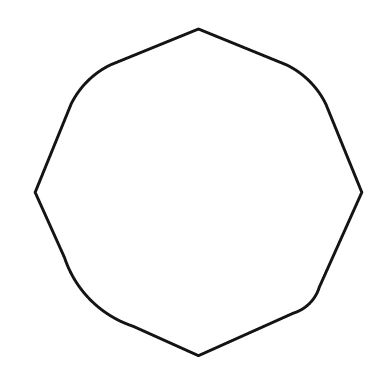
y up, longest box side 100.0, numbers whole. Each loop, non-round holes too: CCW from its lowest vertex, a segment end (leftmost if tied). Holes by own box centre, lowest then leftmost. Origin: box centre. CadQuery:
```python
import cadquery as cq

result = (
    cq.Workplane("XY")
    .moveTo(0.0, -50.0)
    .lineTo(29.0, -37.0)
    .threePointArc((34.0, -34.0), (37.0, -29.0))
    .lineTo(50.0, 0.0)
    .lineTo(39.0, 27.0)
    .threePointArc((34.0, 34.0), (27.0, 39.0))
    .lineTo(0.0, 50.0)
    .lineTo(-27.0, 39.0)
    .threePointArc((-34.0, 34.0), (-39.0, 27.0))
    .lineTo(-50.0, 0.0)
    .lineTo(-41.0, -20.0)
    .threePointArc((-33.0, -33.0), (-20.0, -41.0))
    .close()
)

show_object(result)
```